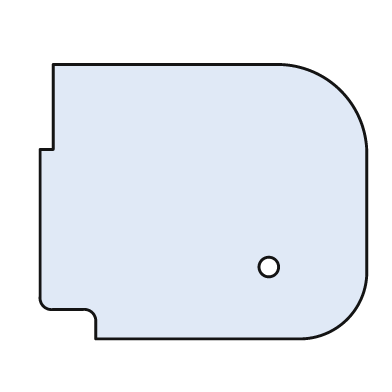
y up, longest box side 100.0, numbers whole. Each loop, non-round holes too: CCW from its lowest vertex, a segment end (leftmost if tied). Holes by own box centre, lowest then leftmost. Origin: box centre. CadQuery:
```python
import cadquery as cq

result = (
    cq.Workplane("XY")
    .moveTo(-33.0, -42.0)
    .lineTo(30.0, -42.0)
    .threePointArc((44.0, -36.0), (50.0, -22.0))
    .lineTo(50.0, 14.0)
    .threePointArc((42.0, 34.0), (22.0, 42.0))
    .lineTo(-46.0, 42.0)
    .lineTo(-46.0, 16.0)
    .lineTo(-50.0, 16.0)
    .lineTo(-50.0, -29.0)
    .threePointArc((-49.0, -32.0), (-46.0, -33.0))
    .lineTo(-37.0, -33.0)
    .threePointArc((-34.0, -34.0), (-33.0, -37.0))
    .close()
    .moveTo(20.0, -20.0)
    .circle(3.0)
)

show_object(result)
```